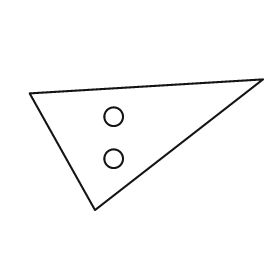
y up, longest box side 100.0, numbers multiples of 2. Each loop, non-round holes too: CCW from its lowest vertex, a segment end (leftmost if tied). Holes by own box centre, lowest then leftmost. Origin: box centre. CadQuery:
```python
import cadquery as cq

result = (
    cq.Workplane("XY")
    .moveTo(-22.0, -28.0)
    .lineTo(50.0, 28.0)
    .lineTo(-50.0, 22.0)
    .close()
    .moveTo(-14.0, -6.0)
    .circle(4.0)
    .moveTo(-14.0, 12.0)
    .circle(4.0)
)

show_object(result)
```